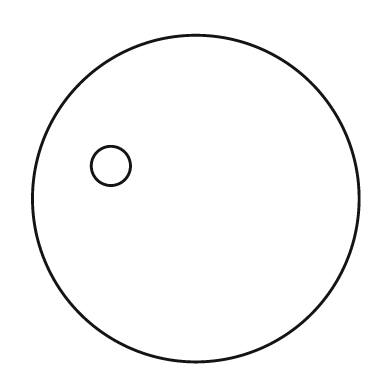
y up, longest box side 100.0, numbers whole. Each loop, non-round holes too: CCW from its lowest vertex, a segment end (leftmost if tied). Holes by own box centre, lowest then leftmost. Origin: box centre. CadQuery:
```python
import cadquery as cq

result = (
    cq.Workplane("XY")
    .moveTo(0.0, 0.0)
    .circle(50.0)
    .moveTo(-26.0, 10.0)
    .circle(6.0)
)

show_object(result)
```